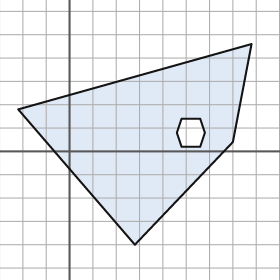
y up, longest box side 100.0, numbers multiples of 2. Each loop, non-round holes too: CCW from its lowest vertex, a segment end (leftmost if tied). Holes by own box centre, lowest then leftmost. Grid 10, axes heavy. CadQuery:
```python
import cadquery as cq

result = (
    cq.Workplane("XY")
    .moveTo(28.0, -40.0)
    .lineTo(70.0, 4.0)
    .lineTo(78.0, 46.0)
    .lineTo(-22.0, 18.0)
    .close()
    .moveTo(48.0, 2.0)
    .lineTo(56.0, 2.0)
    .lineTo(58.0, 8.0)
    .lineTo(56.0, 14.0)
    .lineTo(48.0, 14.0)
    .lineTo(46.0, 8.0)
    .close()
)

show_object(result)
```